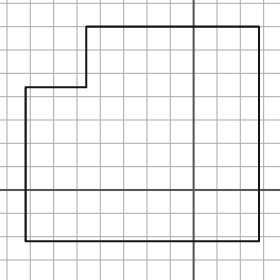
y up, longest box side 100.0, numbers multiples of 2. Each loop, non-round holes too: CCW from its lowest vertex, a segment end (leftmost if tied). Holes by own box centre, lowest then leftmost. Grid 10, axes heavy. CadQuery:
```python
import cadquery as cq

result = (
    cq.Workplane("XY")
    .moveTo(-72.0, -22.0)
    .lineTo(28.0, -22.0)
    .lineTo(28.0, 70.0)
    .lineTo(-46.0, 70.0)
    .lineTo(-46.0, 44.0)
    .lineTo(-72.0, 44.0)
    .close()
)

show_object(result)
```